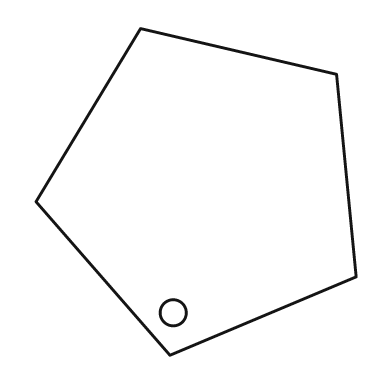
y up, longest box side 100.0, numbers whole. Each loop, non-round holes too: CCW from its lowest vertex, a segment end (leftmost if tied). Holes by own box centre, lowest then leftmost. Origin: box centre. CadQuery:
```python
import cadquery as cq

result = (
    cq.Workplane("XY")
    .moveTo(-8.0, -50.0)
    .lineTo(49.0, -26.0)
    .lineTo(43.0, 36.0)
    .lineTo(-17.0, 50.0)
    .lineTo(-49.0, -3.0)
    .close()
    .moveTo(-7.0, -37.0)
    .circle(4.0)
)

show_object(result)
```